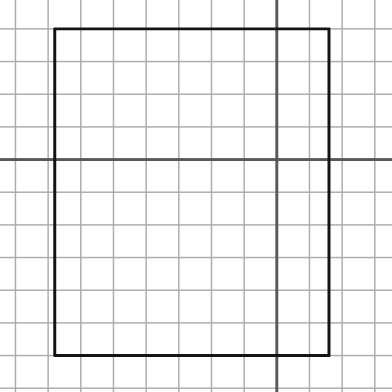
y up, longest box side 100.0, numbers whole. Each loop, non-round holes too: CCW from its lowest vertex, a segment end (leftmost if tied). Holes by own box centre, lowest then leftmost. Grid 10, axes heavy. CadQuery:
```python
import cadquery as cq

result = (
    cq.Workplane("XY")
    .moveTo(-68.0, -60.0)
    .lineTo(16.0, -60.0)
    .lineTo(16.0, 40.0)
    .lineTo(-68.0, 40.0)
    .close()
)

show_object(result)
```